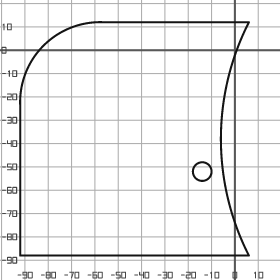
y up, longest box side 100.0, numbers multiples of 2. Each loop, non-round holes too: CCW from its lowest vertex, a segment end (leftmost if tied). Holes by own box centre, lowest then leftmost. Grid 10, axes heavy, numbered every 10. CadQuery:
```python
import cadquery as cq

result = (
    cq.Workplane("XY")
    .moveTo(-92.0, -88.0)
    .lineTo(6.0, -88.0)
    .threePointArc((-6.0, -38.0), (6.0, 12.0))
    .lineTo(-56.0, 12.0)
    .threePointArc((-82.0, 2.0), (-92.0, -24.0))
    .close()
    .moveTo(-14.0, -52.0)
    .circle(4.0)
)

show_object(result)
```